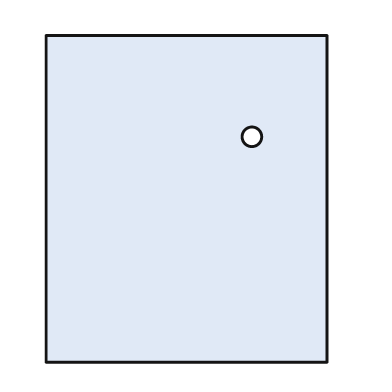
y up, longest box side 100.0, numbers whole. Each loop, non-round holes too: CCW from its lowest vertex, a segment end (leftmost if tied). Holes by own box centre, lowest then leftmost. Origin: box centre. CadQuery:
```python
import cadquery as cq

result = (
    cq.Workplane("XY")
    .moveTo(-43.0, -50.0)
    .lineTo(43.0, -50.0)
    .lineTo(43.0, 50.0)
    .lineTo(-43.0, 50.0)
    .close()
    .moveTo(20.0, 19.0)
    .circle(3.0)
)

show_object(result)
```